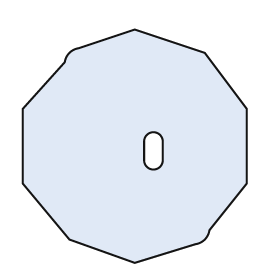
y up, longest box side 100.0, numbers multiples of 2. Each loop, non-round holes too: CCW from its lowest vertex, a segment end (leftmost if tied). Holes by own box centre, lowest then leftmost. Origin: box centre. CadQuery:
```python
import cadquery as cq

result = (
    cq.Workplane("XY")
    .moveTo(0.0, -50.0)
    .lineTo(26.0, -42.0)
    .threePointArc((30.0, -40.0), (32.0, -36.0))
    .lineTo(48.0, -16.0)
    .lineTo(48.0, 16.0)
    .lineTo(30.0, 40.0)
    .lineTo(0.0, 50.0)
    .lineTo(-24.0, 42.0)
    .threePointArc((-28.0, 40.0), (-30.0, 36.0))
    .lineTo(-48.0, 16.0)
    .lineTo(-48.0, -16.0)
    .lineTo(-28.0, -40.0)
    .close()
    .moveTo(4.0, -6.0)
    .threePointArc((8.0, -10.0), (12.0, -6.0))
    .lineTo(12.0, 2.0)
    .threePointArc((8.0, 6.0), (4.0, 2.0))
    .close()
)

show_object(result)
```